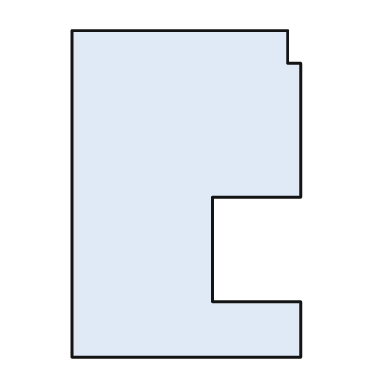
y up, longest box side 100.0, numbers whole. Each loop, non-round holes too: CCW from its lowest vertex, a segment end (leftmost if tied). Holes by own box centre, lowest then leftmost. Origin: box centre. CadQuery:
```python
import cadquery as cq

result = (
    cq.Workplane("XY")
    .moveTo(-35.0, -50.0)
    .lineTo(35.0, -50.0)
    .lineTo(35.0, -33.0)
    .lineTo(8.0, -33.0)
    .lineTo(8.0, -1.0)
    .lineTo(35.0, -1.0)
    .lineTo(35.0, 40.0)
    .lineTo(31.0, 40.0)
    .lineTo(31.0, 50.0)
    .lineTo(-35.0, 50.0)
    .close()
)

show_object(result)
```